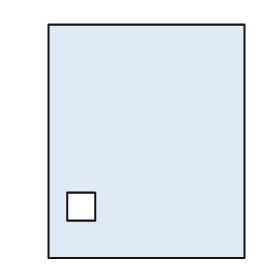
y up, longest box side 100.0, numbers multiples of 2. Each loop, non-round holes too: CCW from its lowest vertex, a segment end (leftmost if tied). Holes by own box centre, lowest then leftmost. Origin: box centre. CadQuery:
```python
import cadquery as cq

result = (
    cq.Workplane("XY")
    .moveTo(-42.0, -50.0)
    .lineTo(42.0, -50.0)
    .lineTo(42.0, 50.0)
    .lineTo(-42.0, 50.0)
    .close()
    .moveTo(-34.0, -34.0)
    .lineTo(-22.0, -34.0)
    .lineTo(-22.0, -22.0)
    .lineTo(-34.0, -22.0)
    .close()
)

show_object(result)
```